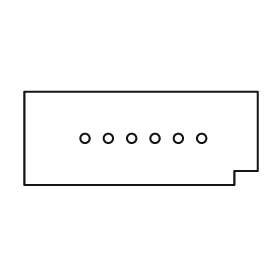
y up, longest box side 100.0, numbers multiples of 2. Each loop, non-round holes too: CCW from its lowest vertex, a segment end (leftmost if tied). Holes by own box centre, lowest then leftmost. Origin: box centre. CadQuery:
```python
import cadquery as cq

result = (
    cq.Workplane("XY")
    .moveTo(-50.0, -20.0)
    .lineTo(40.0, -20.0)
    .lineTo(40.0, -14.0)
    .lineTo(50.0, -14.0)
    .lineTo(50.0, 20.0)
    .lineTo(-50.0, 20.0)
    .close()
    .moveTo(-24.0, 0.0)
    .circle(2.0)
    .moveTo(-14.0, 0.0)
    .circle(2.0)
    .moveTo(-4.0, 0.0)
    .circle(2.0)
    .moveTo(6.0, 0.0)
    .circle(2.0)
    .moveTo(16.0, 0.0)
    .circle(2.0)
    .moveTo(26.0, 0.0)
    .circle(2.0)
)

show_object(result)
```